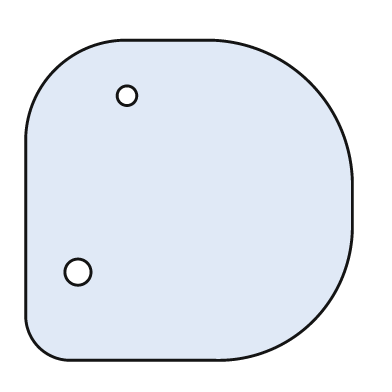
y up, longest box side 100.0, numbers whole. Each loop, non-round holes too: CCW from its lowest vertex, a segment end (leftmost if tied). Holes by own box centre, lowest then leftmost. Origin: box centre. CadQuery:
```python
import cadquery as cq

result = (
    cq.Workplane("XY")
    .moveTo(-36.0, -49.0)
    .lineTo(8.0, -49.0)
    .threePointArc((38.0, -37.0), (50.0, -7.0))
    .lineTo(50.0, 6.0)
    .threePointArc((37.0, 36.0), (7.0, 49.0))
    .lineTo(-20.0, 49.0)
    .threePointArc((-41.0, 40.0), (-50.0, 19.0))
    .lineTo(-50.0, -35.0)
    .threePointArc((-46.0, -45.0), (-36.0, -49.0))
    .close()
    .moveTo(-34.0, -22.0)
    .circle(4.0)
    .moveTo(-19.0, 32.0)
    .circle(3.0)
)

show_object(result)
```